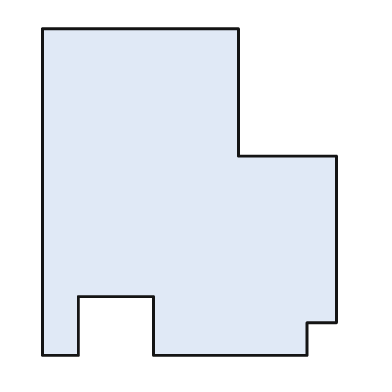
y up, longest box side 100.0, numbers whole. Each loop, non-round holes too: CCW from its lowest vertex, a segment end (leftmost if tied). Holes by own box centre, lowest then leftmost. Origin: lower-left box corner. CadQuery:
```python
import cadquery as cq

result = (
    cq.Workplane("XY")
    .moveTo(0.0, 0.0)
    .lineTo(11.0, 0.0)
    .lineTo(11.0, 18.0)
    .lineTo(34.0, 18.0)
    .lineTo(34.0, 0.0)
    .lineTo(81.0, 0.0)
    .lineTo(81.0, 10.0)
    .lineTo(90.0, 10.0)
    .lineTo(90.0, 61.0)
    .lineTo(60.0, 61.0)
    .lineTo(60.0, 100.0)
    .lineTo(0.0, 100.0)
    .close()
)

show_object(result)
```